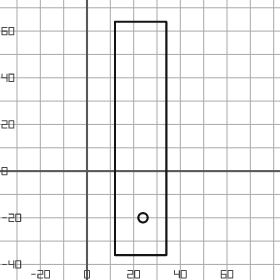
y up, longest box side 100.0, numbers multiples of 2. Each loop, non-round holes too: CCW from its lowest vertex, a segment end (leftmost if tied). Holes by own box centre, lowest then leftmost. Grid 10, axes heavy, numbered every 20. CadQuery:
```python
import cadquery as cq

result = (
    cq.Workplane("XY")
    .moveTo(12.0, -36.0)
    .lineTo(34.0, -36.0)
    .lineTo(34.0, 64.0)
    .lineTo(12.0, 64.0)
    .close()
    .moveTo(24.0, -20.0)
    .circle(2.0)
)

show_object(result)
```